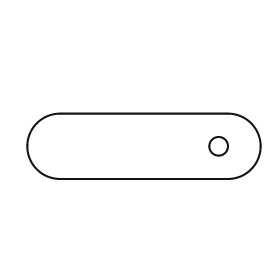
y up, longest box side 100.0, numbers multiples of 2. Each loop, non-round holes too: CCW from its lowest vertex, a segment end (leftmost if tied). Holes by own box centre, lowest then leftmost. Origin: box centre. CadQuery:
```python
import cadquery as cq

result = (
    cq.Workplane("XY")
    .moveTo(-36.0, -14.0)
    .lineTo(36.0, -14.0)
    .threePointArc((50.0, 0.0), (36.0, 14.0))
    .lineTo(-36.0, 14.0)
    .threePointArc((-50.0, 0.0), (-36.0, -14.0))
    .close()
    .moveTo(32.0, 0.0)
    .circle(4.0)
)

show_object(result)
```